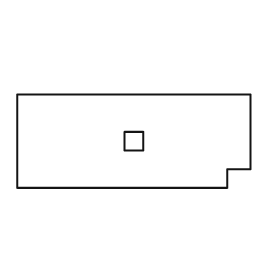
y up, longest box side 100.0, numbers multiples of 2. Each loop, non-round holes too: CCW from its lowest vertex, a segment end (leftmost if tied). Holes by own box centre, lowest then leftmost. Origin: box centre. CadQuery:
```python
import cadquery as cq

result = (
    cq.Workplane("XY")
    .moveTo(-50.0, -20.0)
    .lineTo(40.0, -20.0)
    .lineTo(40.0, -12.0)
    .lineTo(50.0, -12.0)
    .lineTo(50.0, 20.0)
    .lineTo(-50.0, 20.0)
    .close()
    .moveTo(-4.0, -4.0)
    .lineTo(4.0, -4.0)
    .lineTo(4.0, 4.0)
    .lineTo(-4.0, 4.0)
    .close()
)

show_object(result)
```